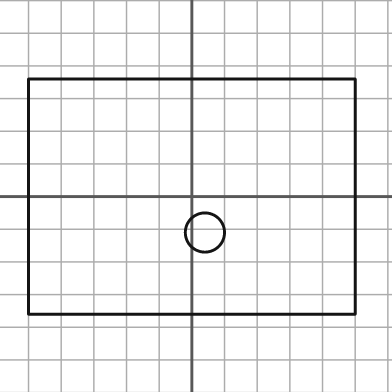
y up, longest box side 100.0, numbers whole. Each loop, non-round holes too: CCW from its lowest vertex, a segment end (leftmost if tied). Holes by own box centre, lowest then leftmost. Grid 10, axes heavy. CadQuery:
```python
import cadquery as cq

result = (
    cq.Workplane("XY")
    .moveTo(-50.0, -36.0)
    .lineTo(50.0, -36.0)
    .lineTo(50.0, 36.0)
    .lineTo(-50.0, 36.0)
    .close()
    .moveTo(4.0, -11.0)
    .circle(6.0)
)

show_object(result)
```